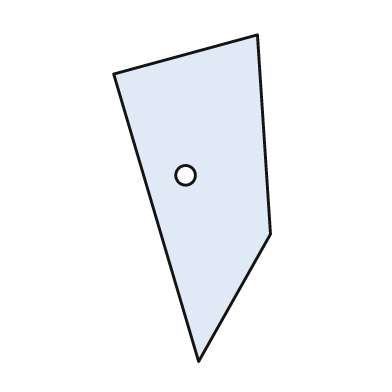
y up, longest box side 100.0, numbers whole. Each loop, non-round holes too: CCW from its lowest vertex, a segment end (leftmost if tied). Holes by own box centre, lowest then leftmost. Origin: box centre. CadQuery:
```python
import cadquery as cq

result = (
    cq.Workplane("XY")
    .moveTo(2.0, -50.0)
    .lineTo(24.0, -11.0)
    .lineTo(20.0, 50.0)
    .lineTo(-24.0, 38.0)
    .close()
    .moveTo(-2.0, 7.0)
    .circle(3.0)
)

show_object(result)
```